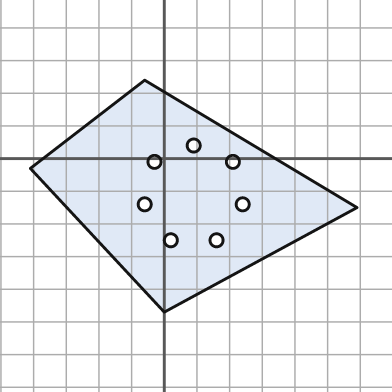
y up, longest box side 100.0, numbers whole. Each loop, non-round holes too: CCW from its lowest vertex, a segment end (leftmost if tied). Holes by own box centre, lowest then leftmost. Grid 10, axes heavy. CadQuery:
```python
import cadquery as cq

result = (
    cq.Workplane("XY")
    .moveTo(0.0, -47.0)
    .lineTo(59.0, -15.0)
    .lineTo(-6.0, 24.0)
    .lineTo(-41.0, -3.0)
    .close()
    .moveTo(2.0, -25.0)
    .circle(2.0)
    .moveTo(16.0, -25.0)
    .circle(2.0)
    .moveTo(-6.0, -14.0)
    .circle(2.0)
    .moveTo(24.0, -14.0)
    .circle(2.0)
    .moveTo(-3.0, -1.0)
    .circle(2.0)
    .moveTo(21.0, -1.0)
    .circle(2.0)
    .moveTo(9.0, 4.0)
    .circle(2.0)
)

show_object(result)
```